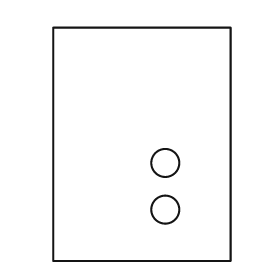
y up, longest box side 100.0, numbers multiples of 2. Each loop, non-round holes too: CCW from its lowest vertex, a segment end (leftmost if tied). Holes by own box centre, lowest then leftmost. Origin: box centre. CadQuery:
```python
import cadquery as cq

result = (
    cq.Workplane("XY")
    .moveTo(-38.0, -50.0)
    .lineTo(38.0, -50.0)
    .lineTo(38.0, 50.0)
    .lineTo(-38.0, 50.0)
    .close()
    .moveTo(10.0, -28.0)
    .circle(6.0)
    .moveTo(10.0, -8.0)
    .circle(6.0)
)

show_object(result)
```